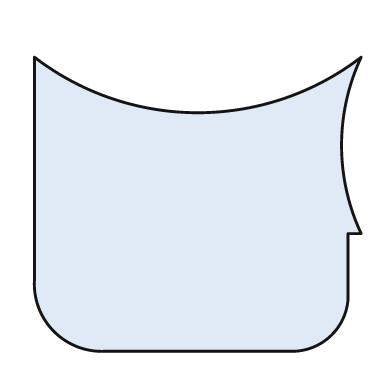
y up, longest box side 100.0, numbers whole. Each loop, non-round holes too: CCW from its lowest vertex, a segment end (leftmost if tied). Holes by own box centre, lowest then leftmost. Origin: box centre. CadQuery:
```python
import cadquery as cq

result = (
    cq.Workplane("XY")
    .moveTo(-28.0, -45.0)
    .lineTo(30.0, -45.0)
    .threePointArc((41.0, -40.0), (46.0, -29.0))
    .lineTo(46.0, -9.0)
    .lineTo(50.0, -9.0)
    .threePointArc((44.0, 18.0), (50.0, 45.0))
    .threePointArc((0.0, 28.0), (-50.0, 45.0))
    .lineTo(-50.0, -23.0)
    .threePointArc((-44.0, -39.0), (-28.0, -45.0))
    .close()
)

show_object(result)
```